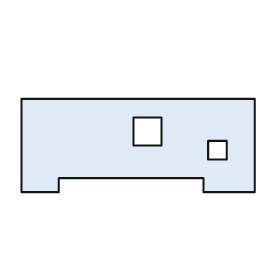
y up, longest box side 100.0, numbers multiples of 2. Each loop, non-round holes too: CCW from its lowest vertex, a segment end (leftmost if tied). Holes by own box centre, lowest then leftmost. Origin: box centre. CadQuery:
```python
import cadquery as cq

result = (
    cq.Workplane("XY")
    .moveTo(-50.0, -20.0)
    .lineTo(-34.0, -20.0)
    .lineTo(-34.0, -14.0)
    .lineTo(28.0, -14.0)
    .lineTo(28.0, -20.0)
    .lineTo(50.0, -20.0)
    .lineTo(50.0, 20.0)
    .lineTo(-50.0, 20.0)
    .close()
    .moveTo(30.0, -6.0)
    .lineTo(38.0, -6.0)
    .lineTo(38.0, 2.0)
    .lineTo(30.0, 2.0)
    .close()
    .moveTo(-2.0, 0.0)
    .lineTo(10.0, 0.0)
    .lineTo(10.0, 12.0)
    .lineTo(-2.0, 12.0)
    .close()
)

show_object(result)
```